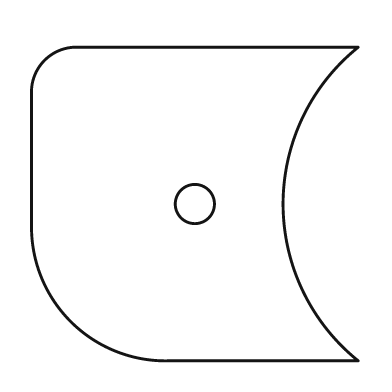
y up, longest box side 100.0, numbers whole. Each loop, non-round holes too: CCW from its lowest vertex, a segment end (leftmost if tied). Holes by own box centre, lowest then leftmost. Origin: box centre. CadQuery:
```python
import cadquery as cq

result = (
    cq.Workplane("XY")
    .moveTo(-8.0, -48.0)
    .lineTo(50.0, -48.0)
    .threePointArc((27.0, 0.0), (50.0, 48.0))
    .lineTo(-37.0, 48.0)
    .threePointArc((-46.0, 44.0), (-50.0, 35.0))
    .lineTo(-50.0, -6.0)
    .threePointArc((-38.0, -36.0), (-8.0, -48.0))
    .close()
    .moveTo(0.0, 0.0)
    .circle(6.0)
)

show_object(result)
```